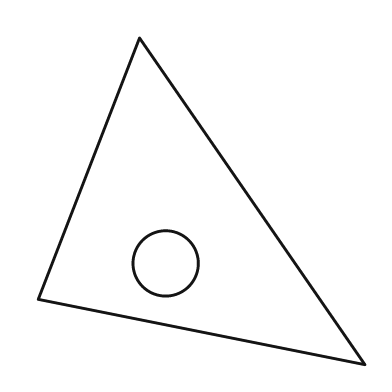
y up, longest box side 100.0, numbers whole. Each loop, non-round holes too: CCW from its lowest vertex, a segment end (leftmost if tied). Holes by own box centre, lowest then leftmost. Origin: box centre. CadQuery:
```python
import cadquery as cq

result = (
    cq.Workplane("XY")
    .moveTo(50.0, -50.0)
    .lineTo(-19.0, 50.0)
    .lineTo(-50.0, -30.0)
    .close()
    .moveTo(-11.0, -19.0)
    .circle(10.0)
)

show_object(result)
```